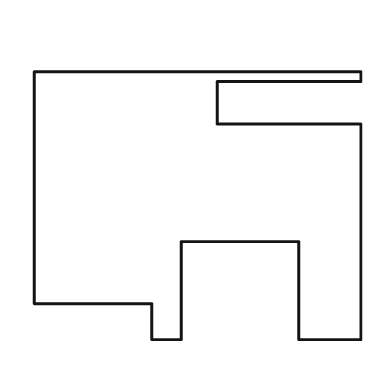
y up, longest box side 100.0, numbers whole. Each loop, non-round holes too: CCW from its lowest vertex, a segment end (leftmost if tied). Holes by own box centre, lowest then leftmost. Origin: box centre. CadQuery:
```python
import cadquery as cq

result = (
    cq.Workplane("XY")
    .moveTo(-14.0, -41.0)
    .lineTo(-5.0, -41.0)
    .lineTo(-5.0, -11.0)
    .lineTo(31.0, -11.0)
    .lineTo(31.0, -41.0)
    .lineTo(50.0, -41.0)
    .lineTo(50.0, 25.0)
    .lineTo(6.0, 25.0)
    .lineTo(6.0, 38.0)
    .lineTo(50.0, 38.0)
    .lineTo(50.0, 41.0)
    .lineTo(-50.0, 41.0)
    .lineTo(-50.0, -30.0)
    .lineTo(-14.0, -30.0)
    .close()
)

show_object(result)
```